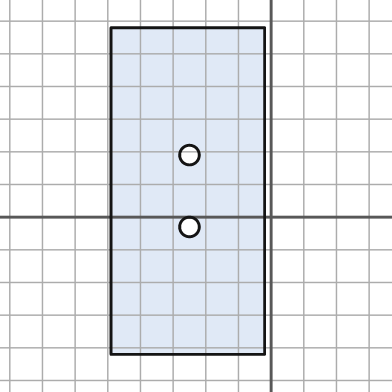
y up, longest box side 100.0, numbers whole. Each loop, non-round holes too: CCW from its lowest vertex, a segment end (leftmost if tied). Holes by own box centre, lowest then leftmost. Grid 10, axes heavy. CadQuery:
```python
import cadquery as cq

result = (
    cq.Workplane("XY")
    .moveTo(-49.0, -42.0)
    .lineTo(-2.0, -42.0)
    .lineTo(-2.0, 58.0)
    .lineTo(-49.0, 58.0)
    .close()
    .moveTo(-25.0, -3.0)
    .circle(3.0)
    .moveTo(-25.0, 19.0)
    .circle(3.0)
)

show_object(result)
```